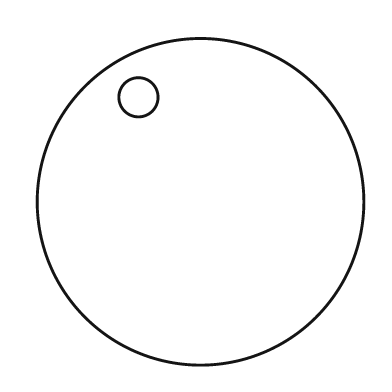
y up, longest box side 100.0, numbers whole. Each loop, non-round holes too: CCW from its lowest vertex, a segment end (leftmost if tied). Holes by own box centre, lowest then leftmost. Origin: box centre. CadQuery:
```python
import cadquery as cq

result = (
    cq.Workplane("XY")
    .moveTo(0.0, 0.0)
    .circle(50.0)
    .moveTo(-19.0, 32.0)
    .circle(6.0)
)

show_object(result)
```